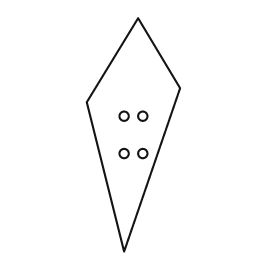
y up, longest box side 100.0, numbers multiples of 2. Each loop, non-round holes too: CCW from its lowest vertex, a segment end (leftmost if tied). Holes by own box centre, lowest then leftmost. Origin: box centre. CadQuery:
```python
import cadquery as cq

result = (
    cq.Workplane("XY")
    .moveTo(-4.0, -50.0)
    .lineTo(20.0, 20.0)
    .lineTo(2.0, 50.0)
    .lineTo(-20.0, 14.0)
    .close()
    .moveTo(-4.0, -8.0)
    .circle(2.0)
    .moveTo(4.0, -8.0)
    .circle(2.0)
    .moveTo(-4.0, 8.0)
    .circle(2.0)
    .moveTo(4.0, 8.0)
    .circle(2.0)
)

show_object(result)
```